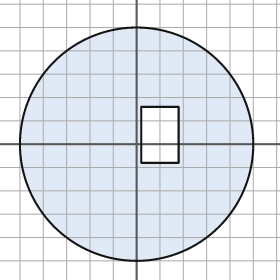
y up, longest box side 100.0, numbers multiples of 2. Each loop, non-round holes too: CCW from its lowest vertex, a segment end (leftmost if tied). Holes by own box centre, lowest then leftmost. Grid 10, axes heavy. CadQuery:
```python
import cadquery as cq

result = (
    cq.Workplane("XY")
    .moveTo(0.0, 0.0)
    .circle(50.0)
    .moveTo(2.0, -8.0)
    .lineTo(18.0, -8.0)
    .lineTo(18.0, 16.0)
    .lineTo(2.0, 16.0)
    .close()
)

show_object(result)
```